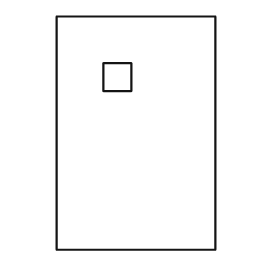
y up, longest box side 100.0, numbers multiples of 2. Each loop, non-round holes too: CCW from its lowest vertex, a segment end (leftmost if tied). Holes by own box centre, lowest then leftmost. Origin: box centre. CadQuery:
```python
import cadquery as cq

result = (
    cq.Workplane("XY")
    .moveTo(-34.0, -50.0)
    .lineTo(34.0, -50.0)
    .lineTo(34.0, 50.0)
    .lineTo(-34.0, 50.0)
    .close()
    .moveTo(-14.0, 18.0)
    .lineTo(-2.0, 18.0)
    .lineTo(-2.0, 30.0)
    .lineTo(-14.0, 30.0)
    .close()
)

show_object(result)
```